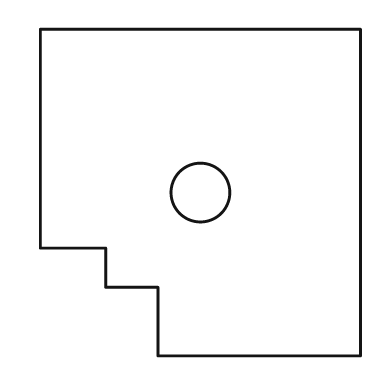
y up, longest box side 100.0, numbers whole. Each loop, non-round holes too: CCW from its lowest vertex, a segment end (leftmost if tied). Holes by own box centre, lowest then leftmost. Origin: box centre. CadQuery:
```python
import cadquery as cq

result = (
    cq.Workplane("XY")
    .moveTo(-13.0, -50.0)
    .lineTo(49.0, -50.0)
    .lineTo(49.0, 50.0)
    .lineTo(-49.0, 50.0)
    .lineTo(-49.0, -17.0)
    .lineTo(-29.0, -17.0)
    .lineTo(-29.0, -29.0)
    .lineTo(-13.0, -29.0)
    .close()
    .moveTo(0.0, 0.0)
    .circle(9.0)
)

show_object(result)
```